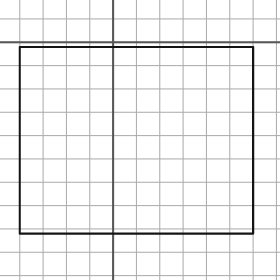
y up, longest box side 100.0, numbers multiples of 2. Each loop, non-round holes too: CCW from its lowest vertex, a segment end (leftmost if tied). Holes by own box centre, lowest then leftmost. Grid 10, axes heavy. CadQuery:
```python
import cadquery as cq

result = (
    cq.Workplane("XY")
    .moveTo(-40.0, -82.0)
    .lineTo(60.0, -82.0)
    .lineTo(60.0, -2.0)
    .lineTo(-40.0, -2.0)
    .close()
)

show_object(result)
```